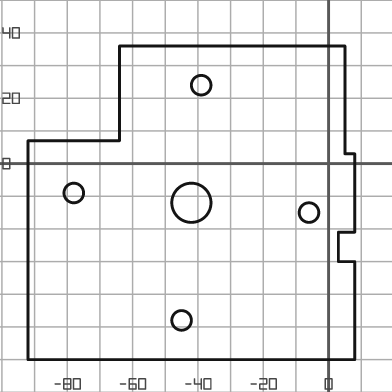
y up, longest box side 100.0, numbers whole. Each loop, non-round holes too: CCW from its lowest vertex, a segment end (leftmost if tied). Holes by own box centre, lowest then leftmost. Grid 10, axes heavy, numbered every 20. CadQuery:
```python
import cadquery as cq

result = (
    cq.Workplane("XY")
    .moveTo(-92.0, -60.0)
    .lineTo(8.0, -60.0)
    .lineTo(8.0, -30.0)
    .lineTo(3.0, -30.0)
    .lineTo(3.0, -21.0)
    .lineTo(8.0, -21.0)
    .lineTo(8.0, 3.0)
    .lineTo(5.0, 3.0)
    .lineTo(5.0, 36.0)
    .lineTo(-64.0, 36.0)
    .lineTo(-64.0, 7.0)
    .lineTo(-92.0, 7.0)
    .close()
    .moveTo(-45.0, -48.0)
    .circle(3.0)
    .moveTo(-6.0, -15.0)
    .circle(3.0)
    .moveTo(-42.0, -12.0)
    .circle(6.0)
    .moveTo(-78.0, -9.0)
    .circle(3.0)
    .moveTo(-39.0, 24.0)
    .circle(3.0)
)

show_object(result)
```